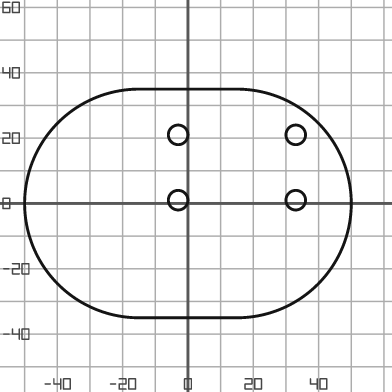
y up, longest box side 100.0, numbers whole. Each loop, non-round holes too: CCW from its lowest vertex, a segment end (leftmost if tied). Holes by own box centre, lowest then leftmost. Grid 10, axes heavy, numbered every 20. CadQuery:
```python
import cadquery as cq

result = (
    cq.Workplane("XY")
    .moveTo(-15.0, -35.0)
    .lineTo(15.0, -35.0)
    .threePointArc((50.0, 0.0), (15.0, 35.0))
    .lineTo(-15.0, 35.0)
    .threePointArc((-50.0, 0.0), (-15.0, -35.0))
    .close()
    .moveTo(-3.0, 1.0)
    .circle(3.0)
    .moveTo(33.0, 1.0)
    .circle(3.0)
    .moveTo(-3.0, 21.0)
    .circle(3.0)
    .moveTo(33.0, 21.0)
    .circle(3.0)
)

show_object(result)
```